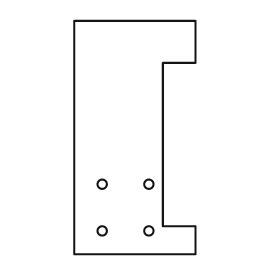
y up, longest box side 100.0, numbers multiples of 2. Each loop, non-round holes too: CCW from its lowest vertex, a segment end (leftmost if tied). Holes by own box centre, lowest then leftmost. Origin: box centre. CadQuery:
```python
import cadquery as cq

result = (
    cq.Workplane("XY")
    .moveTo(-26.0, -50.0)
    .lineTo(26.0, -50.0)
    .lineTo(26.0, -38.0)
    .lineTo(12.0, -38.0)
    .lineTo(12.0, 32.0)
    .lineTo(26.0, 32.0)
    .lineTo(26.0, 50.0)
    .lineTo(-26.0, 50.0)
    .close()
    .moveTo(-14.0, -40.0)
    .circle(2.0)
    .moveTo(6.0, -40.0)
    .circle(2.0)
    .moveTo(-14.0, -20.0)
    .circle(2.0)
    .moveTo(6.0, -20.0)
    .circle(2.0)
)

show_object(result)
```